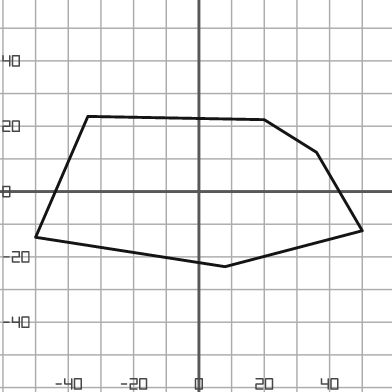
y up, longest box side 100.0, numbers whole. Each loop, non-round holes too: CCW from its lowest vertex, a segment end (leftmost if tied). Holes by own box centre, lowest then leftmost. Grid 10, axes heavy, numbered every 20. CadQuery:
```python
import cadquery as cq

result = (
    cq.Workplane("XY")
    .moveTo(8.0, -23.0)
    .lineTo(50.0, -12.0)
    .lineTo(36.0, 12.0)
    .lineTo(20.0, 22.0)
    .lineTo(-34.0, 23.0)
    .lineTo(-50.0, -14.0)
    .close()
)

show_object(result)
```